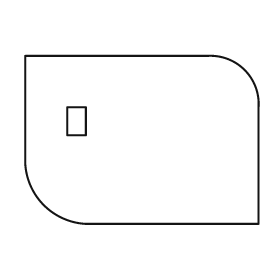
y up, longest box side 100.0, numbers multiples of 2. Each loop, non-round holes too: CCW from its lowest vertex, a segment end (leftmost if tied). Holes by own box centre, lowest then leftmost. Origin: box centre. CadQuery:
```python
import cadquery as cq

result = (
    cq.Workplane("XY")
    .moveTo(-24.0, -36.0)
    .lineTo(50.0, -36.0)
    .lineTo(50.0, 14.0)
    .threePointArc((44.0, 30.0), (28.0, 36.0))
    .lineTo(-50.0, 36.0)
    .lineTo(-50.0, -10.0)
    .threePointArc((-42.0, -28.0), (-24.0, -36.0))
    .close()
    .moveTo(-32.0, 2.0)
    .lineTo(-24.0, 2.0)
    .lineTo(-24.0, 14.0)
    .lineTo(-32.0, 14.0)
    .close()
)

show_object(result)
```